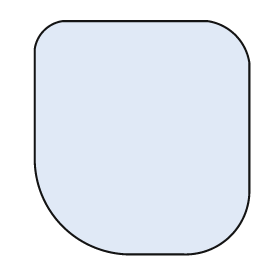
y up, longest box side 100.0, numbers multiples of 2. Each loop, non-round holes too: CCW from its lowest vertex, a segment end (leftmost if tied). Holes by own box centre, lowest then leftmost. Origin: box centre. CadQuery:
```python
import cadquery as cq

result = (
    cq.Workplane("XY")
    .moveTo(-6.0, -50.0)
    .lineTo(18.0, -50.0)
    .threePointArc((38.0, -42.0), (46.0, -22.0))
    .lineTo(46.0, 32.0)
    .threePointArc((40.0, 44.0), (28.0, 50.0))
    .lineTo(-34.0, 50.0)
    .threePointArc((-42.0, 46.0), (-46.0, 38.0))
    .lineTo(-46.0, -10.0)
    .threePointArc((-34.0, -38.0), (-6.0, -50.0))
    .close()
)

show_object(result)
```